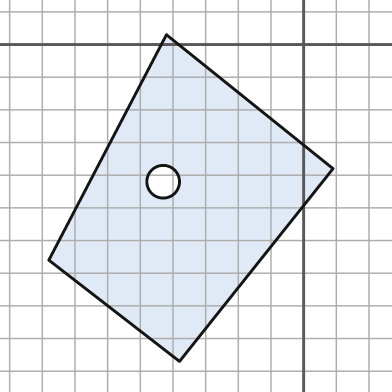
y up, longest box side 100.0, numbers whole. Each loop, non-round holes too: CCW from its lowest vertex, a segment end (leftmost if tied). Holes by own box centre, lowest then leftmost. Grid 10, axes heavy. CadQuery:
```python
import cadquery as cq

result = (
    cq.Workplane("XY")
    .moveTo(-38.0, -97.0)
    .lineTo(9.0, -38.0)
    .lineTo(-42.0, 3.0)
    .lineTo(-78.0, -66.0)
    .close()
    .moveTo(-43.0, -42.0)
    .circle(5.0)
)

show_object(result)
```